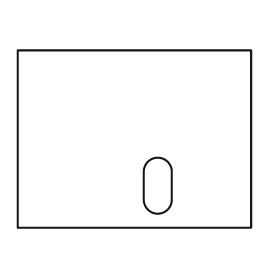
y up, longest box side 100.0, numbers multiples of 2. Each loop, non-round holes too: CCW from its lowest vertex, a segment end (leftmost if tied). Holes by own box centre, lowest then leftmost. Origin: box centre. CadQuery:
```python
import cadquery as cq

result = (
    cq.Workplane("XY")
    .moveTo(-50.0, -38.0)
    .lineTo(50.0, -38.0)
    .lineTo(50.0, 38.0)
    .lineTo(-50.0, 38.0)
    .close()
    .moveTo(4.0, -26.0)
    .threePointArc((10.0, -32.0), (16.0, -26.0))
    .lineTo(16.0, -14.0)
    .threePointArc((10.0, -8.0), (4.0, -14.0))
    .close()
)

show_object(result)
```